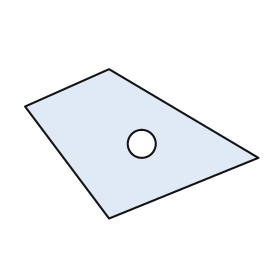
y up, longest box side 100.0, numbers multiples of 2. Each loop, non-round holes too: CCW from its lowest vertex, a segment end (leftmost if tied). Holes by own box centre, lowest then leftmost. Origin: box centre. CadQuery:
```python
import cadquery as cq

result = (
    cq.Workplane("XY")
    .moveTo(-14.0, -32.0)
    .lineTo(50.0, -6.0)
    .lineTo(-14.0, 32.0)
    .lineTo(-50.0, 16.0)
    .close()
    .moveTo(0.0, 0.0)
    .circle(6.0)
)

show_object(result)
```